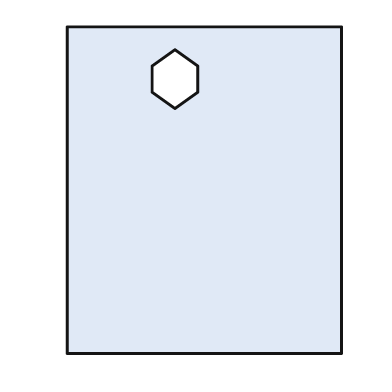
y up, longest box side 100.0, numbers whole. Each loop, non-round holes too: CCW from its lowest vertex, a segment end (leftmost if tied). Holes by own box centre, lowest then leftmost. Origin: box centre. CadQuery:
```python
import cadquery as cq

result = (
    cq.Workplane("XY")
    .moveTo(-42.0, -50.0)
    .lineTo(42.0, -50.0)
    .lineTo(42.0, 50.0)
    .lineTo(-42.0, 50.0)
    .close()
    .moveTo(-9.0, 25.0)
    .lineTo(-2.0, 30.0)
    .lineTo(-2.0, 38.0)
    .lineTo(-9.0, 43.0)
    .lineTo(-16.0, 38.0)
    .lineTo(-16.0, 30.0)
    .close()
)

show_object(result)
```